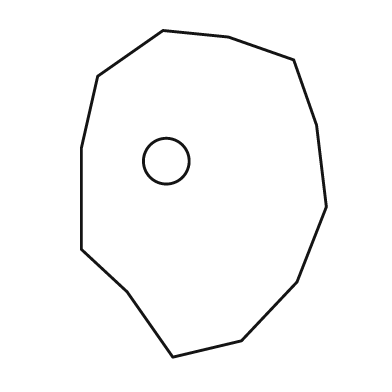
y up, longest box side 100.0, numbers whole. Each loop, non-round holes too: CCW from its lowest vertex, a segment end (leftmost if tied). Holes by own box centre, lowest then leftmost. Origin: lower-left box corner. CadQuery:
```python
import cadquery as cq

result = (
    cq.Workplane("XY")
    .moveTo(28.0, 0.0)
    .lineTo(49.0, 5.0)
    .lineTo(66.0, 23.0)
    .lineTo(75.0, 46.0)
    .lineTo(72.0, 71.0)
    .lineTo(65.0, 91.0)
    .lineTo(45.0, 98.0)
    .lineTo(25.0, 100.0)
    .lineTo(5.0, 86.0)
    .lineTo(0.0, 64.0)
    .lineTo(0.0, 33.0)
    .lineTo(14.0, 20.0)
    .close()
    .moveTo(26.0, 60.0)
    .circle(7.0)
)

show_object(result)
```